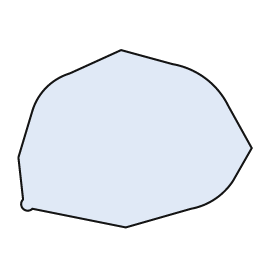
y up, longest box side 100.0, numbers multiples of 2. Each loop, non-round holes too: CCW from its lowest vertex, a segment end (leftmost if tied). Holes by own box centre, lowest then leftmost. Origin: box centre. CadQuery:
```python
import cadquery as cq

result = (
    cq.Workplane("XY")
    .moveTo(-4.0, -38.0)
    .lineTo(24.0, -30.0)
    .threePointArc((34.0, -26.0), (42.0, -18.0))
    .lineTo(50.0, -4.0)
    .lineTo(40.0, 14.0)
    .threePointArc((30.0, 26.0), (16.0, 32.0))
    .lineTo(-6.0, 38.0)
    .lineTo(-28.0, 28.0)
    .threePointArc((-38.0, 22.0), (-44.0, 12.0))
    .lineTo(-50.0, -8.0)
    .lineTo(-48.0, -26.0)
    .threePointArc((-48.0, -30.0), (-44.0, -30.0))
    .close()
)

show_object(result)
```